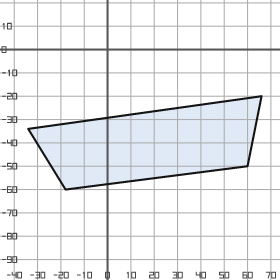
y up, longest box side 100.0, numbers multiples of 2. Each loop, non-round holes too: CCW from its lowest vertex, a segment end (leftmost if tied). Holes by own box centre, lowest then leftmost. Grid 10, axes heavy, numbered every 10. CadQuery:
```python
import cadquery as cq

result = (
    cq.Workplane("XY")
    .moveTo(-18.0, -60.0)
    .lineTo(60.0, -50.0)
    .lineTo(66.0, -20.0)
    .lineTo(-34.0, -34.0)
    .close()
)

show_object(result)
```